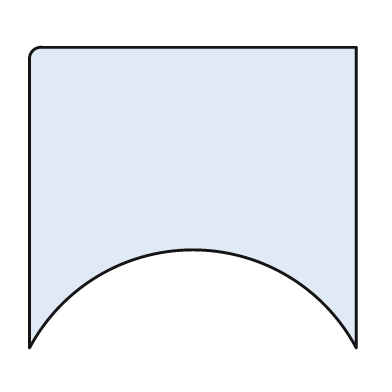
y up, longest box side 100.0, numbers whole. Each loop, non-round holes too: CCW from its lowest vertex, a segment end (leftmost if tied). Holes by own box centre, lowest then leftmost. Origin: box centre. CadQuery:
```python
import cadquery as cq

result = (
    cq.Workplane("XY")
    .moveTo(-50.0, -46.0)
    .threePointArc((0.0, -16.0), (50.0, -46.0))
    .lineTo(50.0, 46.0)
    .lineTo(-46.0, 46.0)
    .threePointArc((-49.0, 45.0), (-50.0, 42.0))
    .close()
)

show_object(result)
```